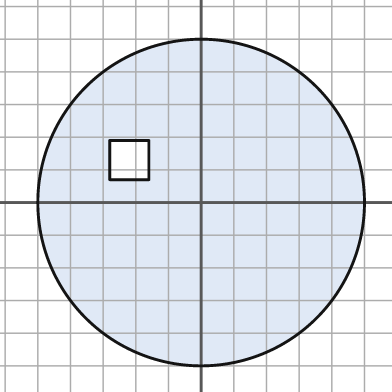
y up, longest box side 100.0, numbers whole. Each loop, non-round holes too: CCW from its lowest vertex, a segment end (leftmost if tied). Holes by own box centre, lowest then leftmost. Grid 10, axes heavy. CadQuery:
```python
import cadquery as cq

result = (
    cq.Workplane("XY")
    .moveTo(0.0, 0.0)
    .circle(50.0)
    .moveTo(-28.0, 7.0)
    .lineTo(-16.0, 7.0)
    .lineTo(-16.0, 19.0)
    .lineTo(-28.0, 19.0)
    .close()
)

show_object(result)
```